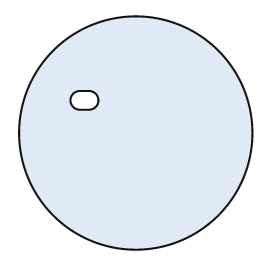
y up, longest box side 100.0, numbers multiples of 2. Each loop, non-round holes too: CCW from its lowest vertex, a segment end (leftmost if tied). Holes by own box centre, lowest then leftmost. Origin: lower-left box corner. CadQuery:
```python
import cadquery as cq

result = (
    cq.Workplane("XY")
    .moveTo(50.0, 50.0)
    .circle(50.0)
    .moveTo(26.0, 60.0)
    .lineTo(30.0, 60.0)
    .threePointArc((34.0, 64.0), (30.0, 68.0))
    .lineTo(26.0, 68.0)
    .threePointArc((22.0, 64.0), (26.0, 60.0))
    .close()
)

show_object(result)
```